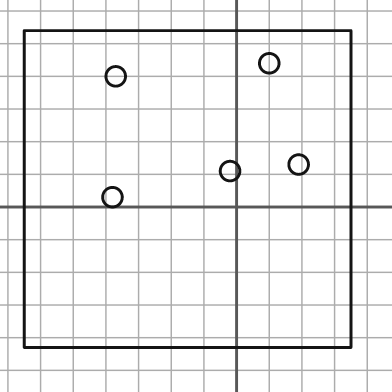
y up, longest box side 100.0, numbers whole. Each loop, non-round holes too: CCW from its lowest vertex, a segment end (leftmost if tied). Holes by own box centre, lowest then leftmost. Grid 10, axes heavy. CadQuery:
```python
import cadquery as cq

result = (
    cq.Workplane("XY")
    .moveTo(-65.0, -43.0)
    .lineTo(35.0, -43.0)
    .lineTo(35.0, 54.0)
    .lineTo(-65.0, 54.0)
    .close()
    .moveTo(-38.0, 3.0)
    .circle(3.0)
    .moveTo(-2.0, 11.0)
    .circle(3.0)
    .moveTo(19.0, 13.0)
    .circle(3.0)
    .moveTo(-37.0, 40.0)
    .circle(3.0)
    .moveTo(10.0, 44.0)
    .circle(3.0)
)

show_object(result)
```